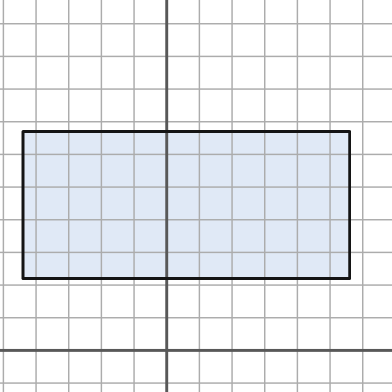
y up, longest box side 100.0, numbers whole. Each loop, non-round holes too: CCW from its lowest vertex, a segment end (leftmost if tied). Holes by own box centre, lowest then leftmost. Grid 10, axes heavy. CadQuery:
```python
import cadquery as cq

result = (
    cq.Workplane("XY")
    .moveTo(-44.0, 22.0)
    .lineTo(56.0, 22.0)
    .lineTo(56.0, 67.0)
    .lineTo(-44.0, 67.0)
    .close()
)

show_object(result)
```